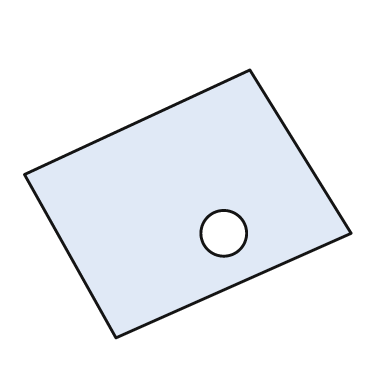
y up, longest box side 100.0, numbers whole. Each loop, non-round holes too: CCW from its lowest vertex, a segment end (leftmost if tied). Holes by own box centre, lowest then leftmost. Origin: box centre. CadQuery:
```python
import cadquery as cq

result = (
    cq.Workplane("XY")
    .moveTo(-22.0, -41.0)
    .lineTo(50.0, -9.0)
    .lineTo(19.0, 41.0)
    .lineTo(-50.0, 9.0)
    .close()
    .moveTo(11.0, -9.0)
    .circle(7.0)
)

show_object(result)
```